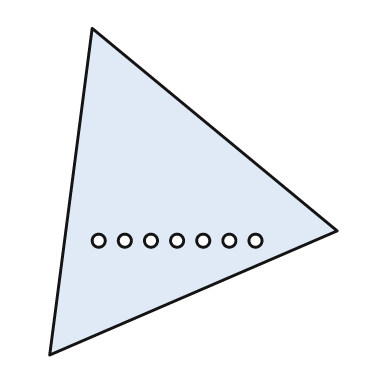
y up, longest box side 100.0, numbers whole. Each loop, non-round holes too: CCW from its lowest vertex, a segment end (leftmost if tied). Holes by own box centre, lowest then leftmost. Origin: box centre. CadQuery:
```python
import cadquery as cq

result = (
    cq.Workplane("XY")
    .moveTo(-44.0, -50.0)
    .lineTo(44.0, -12.0)
    .lineTo(-31.0, 50.0)
    .close()
    .moveTo(-29.0, -15.0)
    .circle(2.0)
    .moveTo(-21.0, -15.0)
    .circle(2.0)
    .moveTo(-13.0, -15.0)
    .circle(2.0)
    .moveTo(-5.0, -15.0)
    .circle(2.0)
    .moveTo(3.0, -15.0)
    .circle(2.0)
    .moveTo(11.0, -15.0)
    .circle(2.0)
    .moveTo(19.0, -15.0)
    .circle(2.0)
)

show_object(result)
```